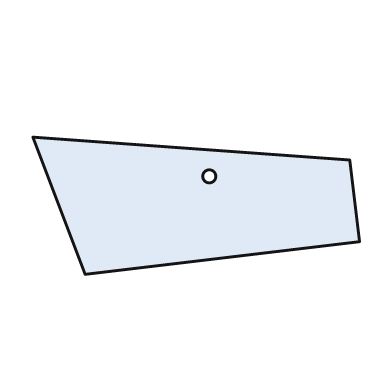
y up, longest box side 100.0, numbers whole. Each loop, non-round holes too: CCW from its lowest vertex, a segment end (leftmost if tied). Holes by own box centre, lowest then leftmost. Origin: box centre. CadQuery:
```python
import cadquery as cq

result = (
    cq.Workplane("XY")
    .moveTo(-34.0, -21.0)
    .lineTo(50.0, -11.0)
    .lineTo(47.0, 14.0)
    .lineTo(-50.0, 21.0)
    .close()
    .moveTo(4.0, 9.0)
    .circle(2.0)
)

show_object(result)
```